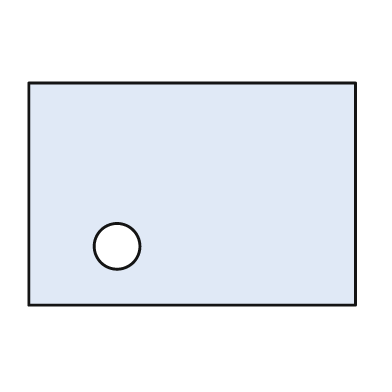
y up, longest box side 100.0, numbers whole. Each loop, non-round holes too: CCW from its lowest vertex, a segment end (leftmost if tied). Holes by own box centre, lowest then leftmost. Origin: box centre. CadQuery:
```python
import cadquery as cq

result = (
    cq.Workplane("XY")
    .moveTo(-50.0, -34.0)
    .lineTo(50.0, -34.0)
    .lineTo(50.0, 34.0)
    .lineTo(-50.0, 34.0)
    .close()
    .moveTo(-23.0, -16.0)
    .circle(7.0)
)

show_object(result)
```